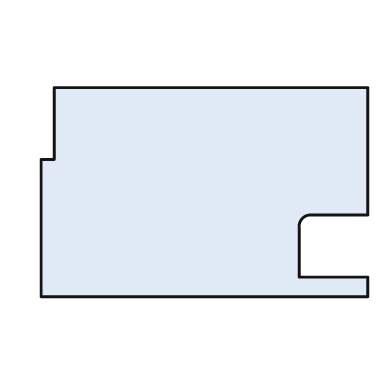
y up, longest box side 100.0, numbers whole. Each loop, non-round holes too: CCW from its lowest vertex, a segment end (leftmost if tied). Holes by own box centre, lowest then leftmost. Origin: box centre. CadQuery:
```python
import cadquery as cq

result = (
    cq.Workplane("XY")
    .moveTo(-50.0, -32.0)
    .lineTo(50.0, -32.0)
    .lineTo(50.0, -26.0)
    .lineTo(29.0, -26.0)
    .lineTo(29.0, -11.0)
    .threePointArc((30.0, -8.0), (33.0, -7.0))
    .lineTo(50.0, -7.0)
    .lineTo(50.0, 32.0)
    .lineTo(-46.0, 32.0)
    .lineTo(-46.0, 10.0)
    .lineTo(-50.0, 10.0)
    .close()
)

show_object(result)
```